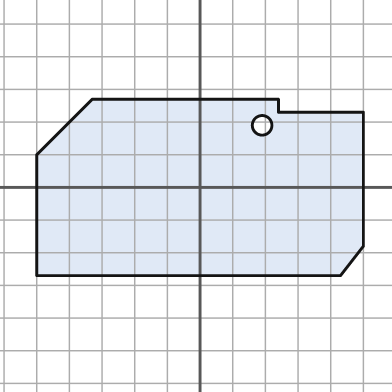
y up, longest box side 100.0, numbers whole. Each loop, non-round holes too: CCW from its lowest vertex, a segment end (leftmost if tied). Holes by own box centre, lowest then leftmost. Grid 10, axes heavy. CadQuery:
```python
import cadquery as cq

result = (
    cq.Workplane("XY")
    .moveTo(-50.0, -27.0)
    .lineTo(43.0, -27.0)
    .lineTo(50.0, -18.0)
    .lineTo(50.0, 23.0)
    .lineTo(24.0, 23.0)
    .lineTo(24.0, 27.0)
    .lineTo(-33.0, 27.0)
    .lineTo(-50.0, 10.0)
    .close()
    .moveTo(19.0, 19.0)
    .circle(3.0)
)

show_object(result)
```